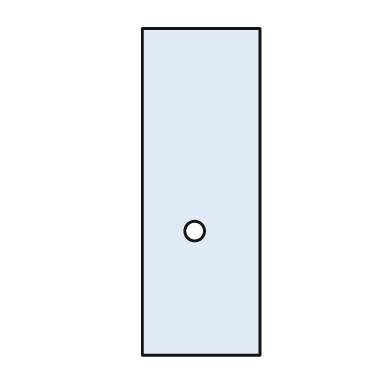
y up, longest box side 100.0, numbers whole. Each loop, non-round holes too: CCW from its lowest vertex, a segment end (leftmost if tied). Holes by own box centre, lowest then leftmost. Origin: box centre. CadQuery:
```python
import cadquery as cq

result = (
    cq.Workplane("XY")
    .moveTo(-18.0, -50.0)
    .lineTo(18.0, -50.0)
    .lineTo(18.0, 50.0)
    .lineTo(-18.0, 50.0)
    .close()
    .moveTo(-2.0, -12.0)
    .circle(3.0)
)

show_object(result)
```